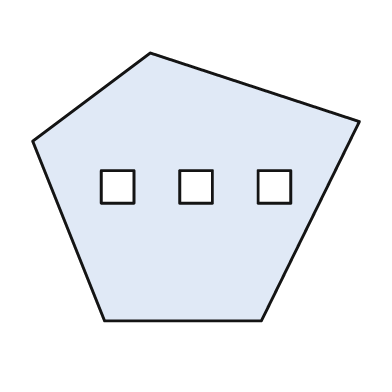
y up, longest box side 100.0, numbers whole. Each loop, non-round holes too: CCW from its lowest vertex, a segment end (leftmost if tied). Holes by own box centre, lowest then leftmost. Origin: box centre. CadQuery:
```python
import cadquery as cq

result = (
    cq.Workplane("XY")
    .moveTo(-28.0, -41.0)
    .lineTo(20.0, -41.0)
    .lineTo(50.0, 20.0)
    .lineTo(-14.0, 41.0)
    .lineTo(-50.0, 14.0)
    .close()
    .moveTo(-29.0, -5.0)
    .lineTo(-19.0, -5.0)
    .lineTo(-19.0, 5.0)
    .lineTo(-29.0, 5.0)
    .close()
    .moveTo(-5.0, -5.0)
    .lineTo(5.0, -5.0)
    .lineTo(5.0, 5.0)
    .lineTo(-5.0, 5.0)
    .close()
    .moveTo(19.0, -5.0)
    .lineTo(29.0, -5.0)
    .lineTo(29.0, 5.0)
    .lineTo(19.0, 5.0)
    .close()
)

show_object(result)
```